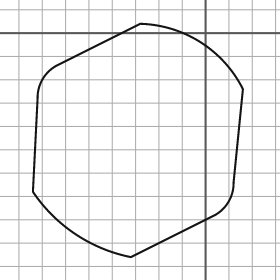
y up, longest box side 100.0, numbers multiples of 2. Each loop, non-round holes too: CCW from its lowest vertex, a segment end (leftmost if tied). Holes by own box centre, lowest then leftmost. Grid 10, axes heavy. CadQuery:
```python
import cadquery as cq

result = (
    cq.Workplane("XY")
    .moveTo(-32.0, -96.0)
    .lineTo(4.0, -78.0)
    .threePointArc((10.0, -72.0), (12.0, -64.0))
    .lineTo(16.0, -24.0)
    .threePointArc((-2.0, -4.0), (-28.0, 4.0))
    .lineTo(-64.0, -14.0)
    .threePointArc((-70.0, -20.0), (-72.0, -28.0))
    .lineTo(-74.0, -68.0)
    .threePointArc((-56.0, -86.0), (-32.0, -96.0))
    .close()
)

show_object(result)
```